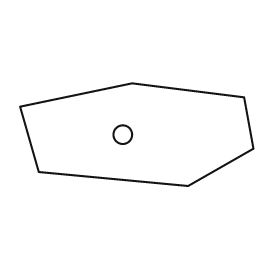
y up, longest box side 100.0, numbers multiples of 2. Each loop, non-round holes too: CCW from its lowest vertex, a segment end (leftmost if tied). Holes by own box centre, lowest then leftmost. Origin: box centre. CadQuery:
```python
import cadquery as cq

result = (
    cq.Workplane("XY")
    .moveTo(22.0, -22.0)
    .lineTo(50.0, -6.0)
    .lineTo(46.0, 16.0)
    .lineTo(-2.0, 22.0)
    .lineTo(-50.0, 12.0)
    .lineTo(-42.0, -16.0)
    .close()
    .moveTo(-6.0, 0.0)
    .circle(4.0)
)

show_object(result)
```